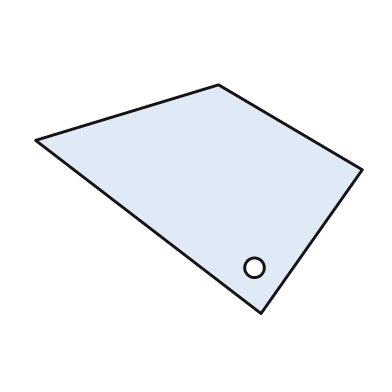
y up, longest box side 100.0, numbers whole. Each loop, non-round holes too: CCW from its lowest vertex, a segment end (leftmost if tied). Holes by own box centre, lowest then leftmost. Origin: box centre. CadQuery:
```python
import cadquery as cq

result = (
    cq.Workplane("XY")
    .moveTo(19.0, -35.0)
    .lineTo(50.0, 9.0)
    .lineTo(6.0, 35.0)
    .lineTo(-50.0, 18.0)
    .close()
    .moveTo(17.0, -21.0)
    .circle(3.0)
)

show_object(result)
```